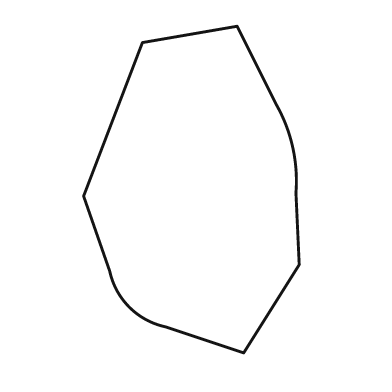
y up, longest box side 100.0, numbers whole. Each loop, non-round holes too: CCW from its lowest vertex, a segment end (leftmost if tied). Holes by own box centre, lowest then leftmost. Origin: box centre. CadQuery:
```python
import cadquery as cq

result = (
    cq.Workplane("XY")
    .moveTo(16.0, -50.0)
    .lineTo(33.0, -23.0)
    .lineTo(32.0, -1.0)
    .threePointArc((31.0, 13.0), (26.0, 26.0))
    .lineTo(14.0, 50.0)
    .lineTo(-15.0, 45.0)
    .lineTo(-33.0, -2.0)
    .lineTo(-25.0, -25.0)
    .threePointArc((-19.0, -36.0), (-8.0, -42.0))
    .close()
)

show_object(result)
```